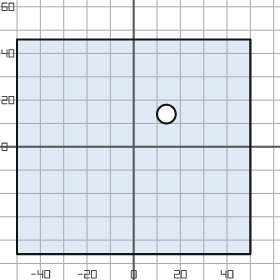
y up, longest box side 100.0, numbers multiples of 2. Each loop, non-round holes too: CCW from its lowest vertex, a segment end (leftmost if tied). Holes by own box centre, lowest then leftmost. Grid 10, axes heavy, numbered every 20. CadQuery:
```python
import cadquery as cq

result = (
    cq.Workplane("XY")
    .moveTo(-50.0, -46.0)
    .lineTo(50.0, -46.0)
    .lineTo(50.0, 46.0)
    .lineTo(-50.0, 46.0)
    .close()
    .moveTo(14.0, 14.0)
    .circle(4.0)
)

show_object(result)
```